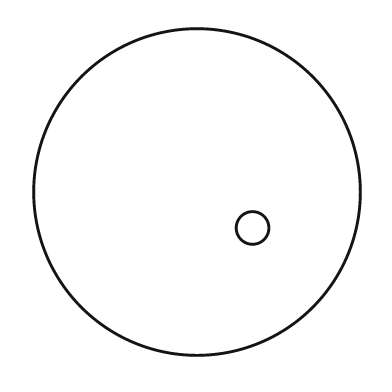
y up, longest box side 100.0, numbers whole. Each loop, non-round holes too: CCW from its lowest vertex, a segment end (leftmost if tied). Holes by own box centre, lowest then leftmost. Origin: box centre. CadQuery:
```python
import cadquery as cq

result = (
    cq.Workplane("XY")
    .moveTo(0.0, 0.0)
    .circle(50.0)
    .moveTo(17.0, -11.0)
    .circle(5.0)
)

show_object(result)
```